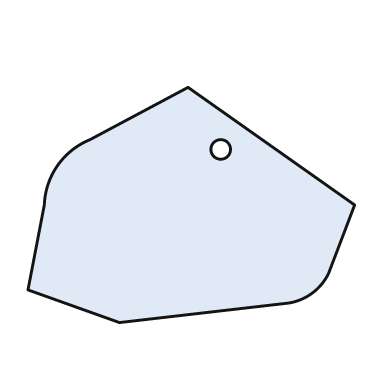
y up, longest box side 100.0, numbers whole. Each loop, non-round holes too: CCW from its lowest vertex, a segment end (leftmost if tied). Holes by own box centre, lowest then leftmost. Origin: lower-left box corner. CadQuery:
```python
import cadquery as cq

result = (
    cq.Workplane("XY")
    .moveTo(28.0, 0.0)
    .lineTo(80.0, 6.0)
    .threePointArc((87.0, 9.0), (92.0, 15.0))
    .lineTo(100.0, 36.0)
    .lineTo(49.0, 72.0)
    .lineTo(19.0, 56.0)
    .threePointArc((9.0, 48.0), (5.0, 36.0))
    .lineTo(0.0, 10.0)
    .close()
    .moveTo(59.0, 53.0)
    .circle(3.0)
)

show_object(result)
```